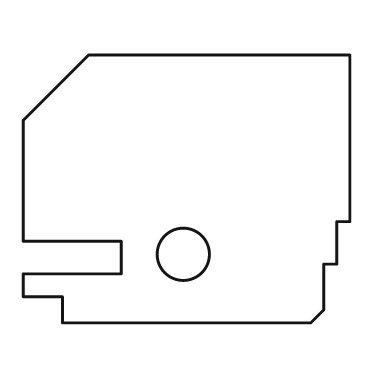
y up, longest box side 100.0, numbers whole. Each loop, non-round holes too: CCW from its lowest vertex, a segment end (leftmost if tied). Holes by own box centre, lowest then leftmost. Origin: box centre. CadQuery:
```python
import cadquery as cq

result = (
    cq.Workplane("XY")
    .moveTo(-38.0, -41.0)
    .lineTo(38.0, -41.0)
    .lineTo(42.0, -37.0)
    .lineTo(42.0, -23.0)
    .lineTo(46.0, -23.0)
    .lineTo(46.0, -10.0)
    .lineTo(50.0, -10.0)
    .lineTo(50.0, 41.0)
    .lineTo(-30.0, 41.0)
    .lineTo(-50.0, 21.0)
    .lineTo(-50.0, -16.0)
    .lineTo(-20.0, -16.0)
    .lineTo(-20.0, -26.0)
    .lineTo(-50.0, -26.0)
    .lineTo(-50.0, -33.0)
    .lineTo(-38.0, -33.0)
    .close()
    .moveTo(-1.0, -20.0)
    .circle(8.0)
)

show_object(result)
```